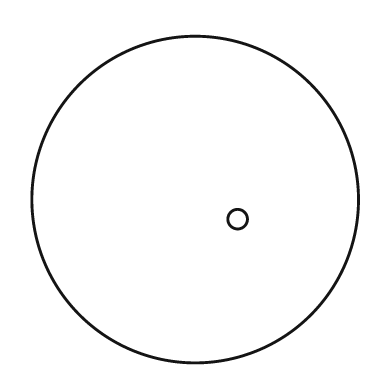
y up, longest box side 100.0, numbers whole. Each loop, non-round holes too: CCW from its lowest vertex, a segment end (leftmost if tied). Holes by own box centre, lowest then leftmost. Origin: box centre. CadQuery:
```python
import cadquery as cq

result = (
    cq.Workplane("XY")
    .moveTo(0.0, 0.0)
    .circle(50.0)
    .moveTo(13.0, -6.0)
    .circle(3.0)
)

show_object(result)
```